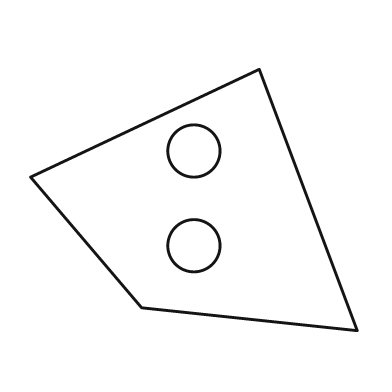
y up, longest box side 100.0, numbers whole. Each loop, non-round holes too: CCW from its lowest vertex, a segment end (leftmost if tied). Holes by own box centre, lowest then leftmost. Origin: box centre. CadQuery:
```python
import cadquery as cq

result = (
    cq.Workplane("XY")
    .moveTo(50.0, -40.0)
    .lineTo(20.0, 40.0)
    .lineTo(-50.0, 7.0)
    .lineTo(-16.0, -33.0)
    .close()
    .moveTo(0.0, -14.0)
    .circle(8.0)
    .moveTo(0.0, 15.0)
    .circle(8.0)
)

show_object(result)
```